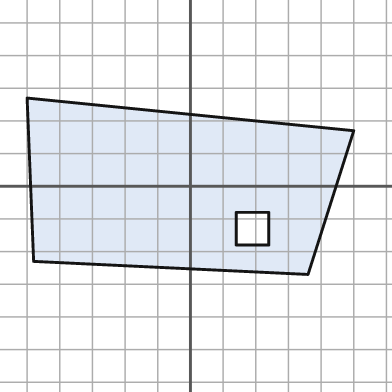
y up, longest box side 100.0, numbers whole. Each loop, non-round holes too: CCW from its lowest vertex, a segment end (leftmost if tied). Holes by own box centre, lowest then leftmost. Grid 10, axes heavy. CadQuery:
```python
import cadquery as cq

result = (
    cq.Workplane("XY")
    .moveTo(36.0, -27.0)
    .lineTo(50.0, 17.0)
    .lineTo(-50.0, 27.0)
    .lineTo(-48.0, -23.0)
    .close()
    .moveTo(14.0, -18.0)
    .lineTo(24.0, -18.0)
    .lineTo(24.0, -8.0)
    .lineTo(14.0, -8.0)
    .close()
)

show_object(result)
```